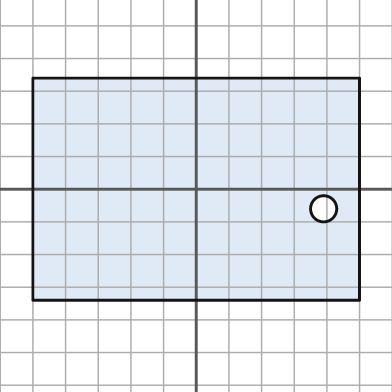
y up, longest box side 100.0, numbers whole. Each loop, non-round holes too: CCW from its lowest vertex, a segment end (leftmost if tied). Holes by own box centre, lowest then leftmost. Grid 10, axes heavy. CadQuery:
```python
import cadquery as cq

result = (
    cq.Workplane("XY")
    .moveTo(-50.0, -34.0)
    .lineTo(50.0, -34.0)
    .lineTo(50.0, 34.0)
    .lineTo(-50.0, 34.0)
    .close()
    .moveTo(39.0, -6.0)
    .circle(4.0)
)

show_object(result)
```